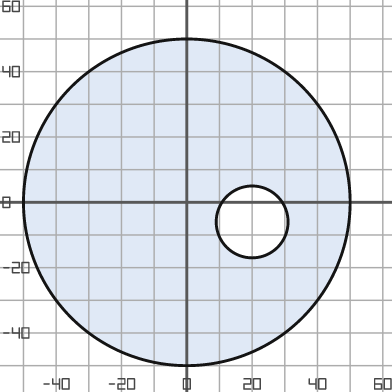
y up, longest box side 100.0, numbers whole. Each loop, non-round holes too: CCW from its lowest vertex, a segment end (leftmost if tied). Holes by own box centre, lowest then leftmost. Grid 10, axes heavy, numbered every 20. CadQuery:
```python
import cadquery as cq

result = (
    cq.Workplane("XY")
    .moveTo(0.0, 0.0)
    .circle(50.0)
    .moveTo(20.0, -6.0)
    .circle(11.0)
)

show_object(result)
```